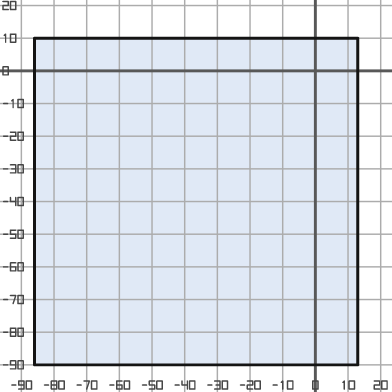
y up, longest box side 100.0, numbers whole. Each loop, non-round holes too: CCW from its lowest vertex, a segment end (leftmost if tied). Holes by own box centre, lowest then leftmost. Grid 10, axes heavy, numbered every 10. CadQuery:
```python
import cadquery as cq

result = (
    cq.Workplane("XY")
    .moveTo(-86.0, -90.0)
    .lineTo(13.0, -90.0)
    .lineTo(13.0, 10.0)
    .lineTo(-86.0, 10.0)
    .close()
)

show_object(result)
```